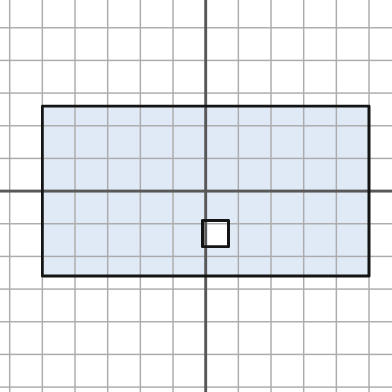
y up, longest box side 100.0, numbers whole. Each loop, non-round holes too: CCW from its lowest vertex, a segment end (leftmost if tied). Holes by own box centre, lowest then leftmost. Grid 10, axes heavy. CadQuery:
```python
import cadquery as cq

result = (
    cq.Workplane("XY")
    .moveTo(-50.0, -26.0)
    .lineTo(50.0, -26.0)
    .lineTo(50.0, 26.0)
    .lineTo(-50.0, 26.0)
    .close()
    .moveTo(-1.0, -17.0)
    .lineTo(7.0, -17.0)
    .lineTo(7.0, -9.0)
    .lineTo(-1.0, -9.0)
    .close()
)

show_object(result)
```